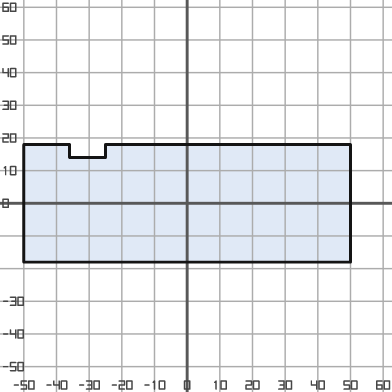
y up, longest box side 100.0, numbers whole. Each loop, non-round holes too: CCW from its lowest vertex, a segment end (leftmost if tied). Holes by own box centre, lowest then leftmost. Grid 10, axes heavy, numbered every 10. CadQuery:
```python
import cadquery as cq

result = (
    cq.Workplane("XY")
    .moveTo(-50.0, -18.0)
    .lineTo(50.0, -18.0)
    .lineTo(50.0, 18.0)
    .lineTo(-25.0, 18.0)
    .lineTo(-25.0, 14.0)
    .lineTo(-36.0, 14.0)
    .lineTo(-36.0, 18.0)
    .lineTo(-50.0, 18.0)
    .close()
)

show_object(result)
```